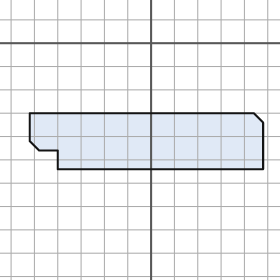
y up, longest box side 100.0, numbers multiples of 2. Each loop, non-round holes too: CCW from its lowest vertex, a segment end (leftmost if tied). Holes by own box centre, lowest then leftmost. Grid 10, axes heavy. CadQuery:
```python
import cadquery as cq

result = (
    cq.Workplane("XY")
    .moveTo(-40.0, -54.0)
    .lineTo(48.0, -54.0)
    .lineTo(48.0, -34.0)
    .lineTo(44.0, -30.0)
    .lineTo(-52.0, -30.0)
    .lineTo(-52.0, -42.0)
    .lineTo(-48.0, -46.0)
    .lineTo(-40.0, -46.0)
    .close()
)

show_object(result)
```